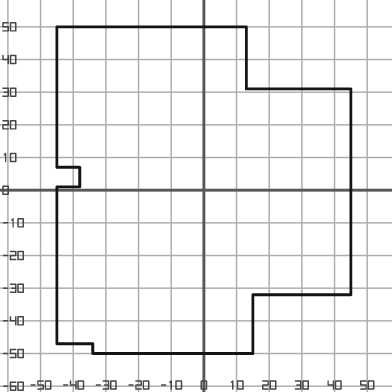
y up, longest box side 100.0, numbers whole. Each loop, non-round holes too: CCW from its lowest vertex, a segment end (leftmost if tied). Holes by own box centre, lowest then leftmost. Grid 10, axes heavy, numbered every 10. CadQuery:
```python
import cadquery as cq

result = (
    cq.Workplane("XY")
    .moveTo(-34.0, -50.0)
    .lineTo(15.0, -50.0)
    .lineTo(15.0, -32.0)
    .lineTo(45.0, -32.0)
    .lineTo(45.0, 31.0)
    .lineTo(13.0, 31.0)
    .lineTo(13.0, 50.0)
    .lineTo(-45.0, 50.0)
    .lineTo(-45.0, 7.0)
    .lineTo(-38.0, 7.0)
    .lineTo(-38.0, 1.0)
    .lineTo(-45.0, 1.0)
    .lineTo(-45.0, -47.0)
    .lineTo(-34.0, -47.0)
    .close()
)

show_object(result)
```